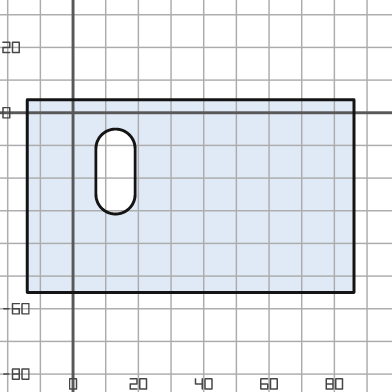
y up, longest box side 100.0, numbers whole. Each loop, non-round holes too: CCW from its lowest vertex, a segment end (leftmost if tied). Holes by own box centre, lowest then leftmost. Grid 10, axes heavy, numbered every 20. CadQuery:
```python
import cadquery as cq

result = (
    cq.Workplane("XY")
    .moveTo(-14.0, -55.0)
    .lineTo(86.0, -55.0)
    .lineTo(86.0, 4.0)
    .lineTo(-14.0, 4.0)
    .close()
    .moveTo(7.0, -25.0)
    .threePointArc((13.0, -31.0), (19.0, -25.0))
    .lineTo(19.0, -11.0)
    .threePointArc((13.0, -5.0), (7.0, -11.0))
    .close()
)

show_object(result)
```